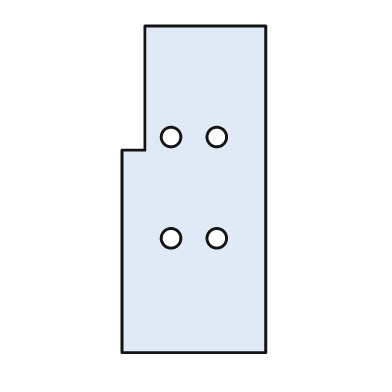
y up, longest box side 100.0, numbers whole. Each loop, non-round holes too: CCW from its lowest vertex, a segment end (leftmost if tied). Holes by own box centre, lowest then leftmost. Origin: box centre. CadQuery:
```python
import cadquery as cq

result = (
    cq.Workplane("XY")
    .moveTo(-22.0, -50.0)
    .lineTo(22.0, -50.0)
    .lineTo(22.0, 50.0)
    .lineTo(-15.0, 50.0)
    .lineTo(-15.0, 12.0)
    .lineTo(-22.0, 12.0)
    .close()
    .moveTo(-7.0, -15.0)
    .circle(3.0)
    .moveTo(7.0, -15.0)
    .circle(3.0)
    .moveTo(-7.0, 16.0)
    .circle(3.0)
    .moveTo(7.0, 16.0)
    .circle(3.0)
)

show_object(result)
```